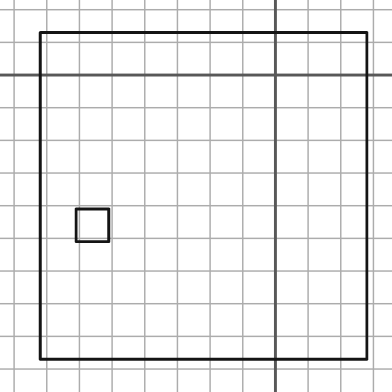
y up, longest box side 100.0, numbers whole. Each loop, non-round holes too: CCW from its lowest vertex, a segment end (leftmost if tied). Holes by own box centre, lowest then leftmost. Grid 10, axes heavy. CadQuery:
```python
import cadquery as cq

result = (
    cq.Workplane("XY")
    .moveTo(-72.0, -87.0)
    .lineTo(28.0, -87.0)
    .lineTo(28.0, 13.0)
    .lineTo(-72.0, 13.0)
    .close()
    .moveTo(-61.0, -51.0)
    .lineTo(-51.0, -51.0)
    .lineTo(-51.0, -41.0)
    .lineTo(-61.0, -41.0)
    .close()
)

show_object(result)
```